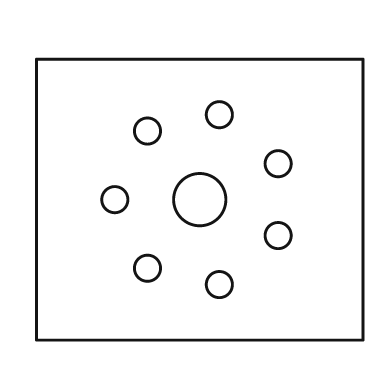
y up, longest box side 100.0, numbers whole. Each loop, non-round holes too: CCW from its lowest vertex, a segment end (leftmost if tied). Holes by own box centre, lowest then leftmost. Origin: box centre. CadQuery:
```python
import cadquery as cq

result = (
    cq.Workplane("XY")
    .moveTo(-50.0, -43.0)
    .lineTo(50.0, -43.0)
    .lineTo(50.0, 43.0)
    .lineTo(-50.0, 43.0)
    .close()
    .moveTo(6.0, -26.0)
    .circle(4.0)
    .moveTo(-16.0, -21.0)
    .circle(4.0)
    .moveTo(24.0, -11.0)
    .circle(4.0)
    .moveTo(-26.0, 0.0)
    .circle(4.0)
    .moveTo(0.0, 0.0)
    .circle(8.0)
    .moveTo(24.0, 11.0)
    .circle(4.0)
    .moveTo(-16.0, 21.0)
    .circle(4.0)
    .moveTo(6.0, 26.0)
    .circle(4.0)
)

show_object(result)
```